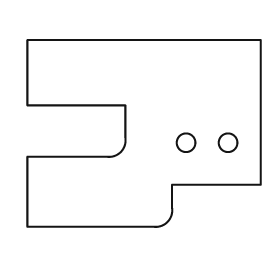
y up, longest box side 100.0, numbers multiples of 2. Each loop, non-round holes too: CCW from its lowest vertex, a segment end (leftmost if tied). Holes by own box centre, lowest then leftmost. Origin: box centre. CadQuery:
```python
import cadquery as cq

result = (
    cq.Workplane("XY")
    .moveTo(-50.0, -40.0)
    .lineTo(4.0, -40.0)
    .threePointArc((10.0, -38.0), (12.0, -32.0))
    .lineTo(12.0, -22.0)
    .lineTo(50.0, -22.0)
    .lineTo(50.0, 40.0)
    .lineTo(-50.0, 40.0)
    .lineTo(-50.0, 12.0)
    .lineTo(-8.0, 12.0)
    .lineTo(-8.0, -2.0)
    .threePointArc((-10.0, -8.0), (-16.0, -10.0))
    .lineTo(-50.0, -10.0)
    .close()
    .moveTo(18.0, -4.0)
    .circle(4.0)
    .moveTo(36.0, -4.0)
    .circle(4.0)
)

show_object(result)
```